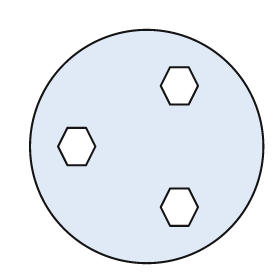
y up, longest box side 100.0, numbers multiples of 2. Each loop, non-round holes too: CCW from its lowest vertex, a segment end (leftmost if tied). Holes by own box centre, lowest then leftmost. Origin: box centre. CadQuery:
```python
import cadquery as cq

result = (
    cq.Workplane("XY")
    .moveTo(0.0, 0.0)
    .circle(50.0)
    .moveTo(10.0, -34.0)
    .lineTo(18.0, -34.0)
    .lineTo(22.0, -26.0)
    .lineTo(18.0, -18.0)
    .lineTo(10.0, -18.0)
    .lineTo(6.0, -26.0)
    .close()
    .moveTo(-34.0, -8.0)
    .lineTo(-26.0, -8.0)
    .lineTo(-22.0, 0.0)
    .lineTo(-26.0, 8.0)
    .lineTo(-34.0, 8.0)
    .lineTo(-38.0, 0.0)
    .close()
    .moveTo(10.0, 18.0)
    .lineTo(18.0, 18.0)
    .lineTo(22.0, 26.0)
    .lineTo(18.0, 34.0)
    .lineTo(10.0, 34.0)
    .lineTo(6.0, 26.0)
    .close()
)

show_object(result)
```